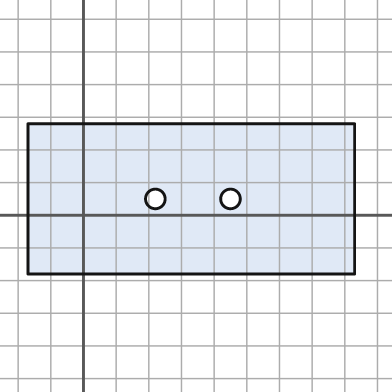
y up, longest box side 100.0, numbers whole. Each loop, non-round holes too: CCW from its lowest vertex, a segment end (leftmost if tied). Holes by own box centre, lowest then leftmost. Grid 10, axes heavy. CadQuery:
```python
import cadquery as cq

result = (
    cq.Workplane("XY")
    .moveTo(-17.0, -18.0)
    .lineTo(83.0, -18.0)
    .lineTo(83.0, 28.0)
    .lineTo(-17.0, 28.0)
    .close()
    .moveTo(22.0, 5.0)
    .circle(3.0)
    .moveTo(45.0, 5.0)
    .circle(3.0)
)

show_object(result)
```